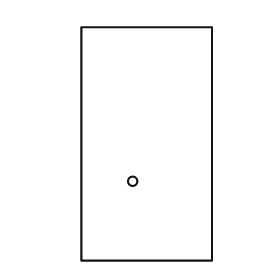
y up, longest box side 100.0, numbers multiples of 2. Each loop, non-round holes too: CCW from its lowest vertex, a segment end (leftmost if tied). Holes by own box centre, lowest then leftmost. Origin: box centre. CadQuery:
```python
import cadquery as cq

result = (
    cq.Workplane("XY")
    .moveTo(-28.0, -50.0)
    .lineTo(28.0, -50.0)
    .lineTo(28.0, 50.0)
    .lineTo(-28.0, 50.0)
    .close()
    .moveTo(-6.0, -16.0)
    .circle(2.0)
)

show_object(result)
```